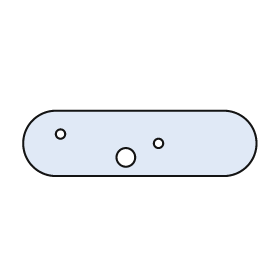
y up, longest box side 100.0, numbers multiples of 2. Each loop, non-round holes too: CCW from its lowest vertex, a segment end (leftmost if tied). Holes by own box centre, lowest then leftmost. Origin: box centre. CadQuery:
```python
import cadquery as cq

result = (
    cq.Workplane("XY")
    .moveTo(-36.0, -14.0)
    .lineTo(36.0, -14.0)
    .threePointArc((50.0, 0.0), (36.0, 14.0))
    .lineTo(-36.0, 14.0)
    .threePointArc((-50.0, 0.0), (-36.0, -14.0))
    .close()
    .moveTo(-6.0, -6.0)
    .circle(4.0)
    .moveTo(8.0, 0.0)
    .circle(2.0)
    .moveTo(-34.0, 4.0)
    .circle(2.0)
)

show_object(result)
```